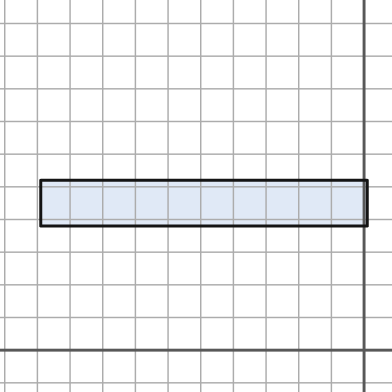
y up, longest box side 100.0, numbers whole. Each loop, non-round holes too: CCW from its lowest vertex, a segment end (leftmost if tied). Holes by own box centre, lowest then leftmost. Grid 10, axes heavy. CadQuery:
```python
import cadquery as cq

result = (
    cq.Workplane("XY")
    .moveTo(-99.0, 38.0)
    .lineTo(1.0, 38.0)
    .lineTo(1.0, 52.0)
    .lineTo(-99.0, 52.0)
    .close()
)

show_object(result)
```